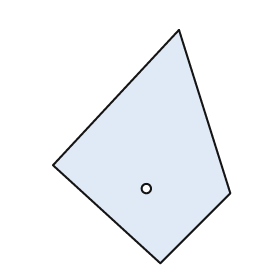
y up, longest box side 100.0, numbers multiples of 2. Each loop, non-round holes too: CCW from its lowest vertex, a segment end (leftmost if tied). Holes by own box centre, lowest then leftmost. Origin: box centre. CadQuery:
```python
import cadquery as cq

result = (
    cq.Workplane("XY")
    .moveTo(8.0, -50.0)
    .lineTo(38.0, -20.0)
    .lineTo(16.0, 50.0)
    .lineTo(-38.0, -8.0)
    .close()
    .moveTo(2.0, -18.0)
    .circle(2.0)
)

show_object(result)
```